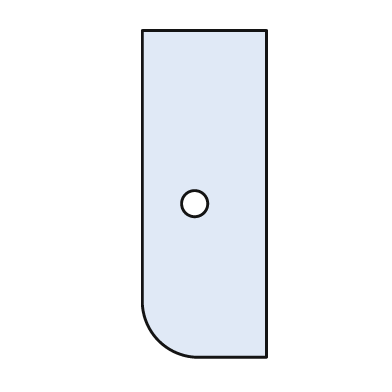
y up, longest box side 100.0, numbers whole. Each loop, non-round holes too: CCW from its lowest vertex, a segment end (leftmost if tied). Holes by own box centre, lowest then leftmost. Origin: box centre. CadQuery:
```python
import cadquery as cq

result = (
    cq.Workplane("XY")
    .moveTo(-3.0, -50.0)
    .lineTo(19.0, -50.0)
    .lineTo(19.0, 50.0)
    .lineTo(-19.0, 50.0)
    .lineTo(-19.0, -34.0)
    .threePointArc((-14.0, -45.0), (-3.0, -50.0))
    .close()
    .moveTo(-3.0, -3.0)
    .circle(4.0)
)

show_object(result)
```